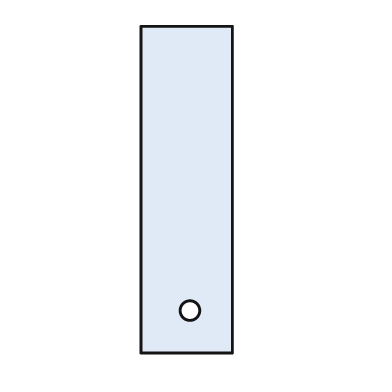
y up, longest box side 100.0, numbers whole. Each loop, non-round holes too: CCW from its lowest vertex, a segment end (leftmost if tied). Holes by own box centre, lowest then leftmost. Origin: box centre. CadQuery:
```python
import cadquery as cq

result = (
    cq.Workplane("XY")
    .moveTo(-14.0, -50.0)
    .lineTo(14.0, -50.0)
    .lineTo(14.0, 50.0)
    .lineTo(-14.0, 50.0)
    .close()
    .moveTo(1.0, -37.0)
    .circle(3.0)
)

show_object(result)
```